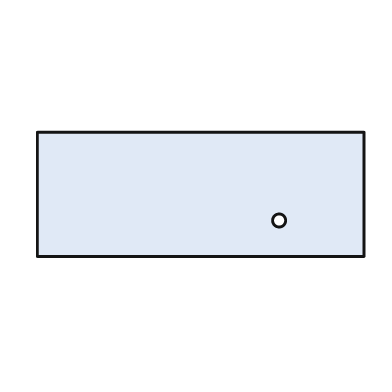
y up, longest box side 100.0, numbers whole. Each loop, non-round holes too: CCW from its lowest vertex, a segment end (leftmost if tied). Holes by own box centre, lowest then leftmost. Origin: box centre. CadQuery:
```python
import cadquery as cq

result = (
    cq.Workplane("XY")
    .moveTo(-50.0, -19.0)
    .lineTo(50.0, -19.0)
    .lineTo(50.0, 19.0)
    .lineTo(-50.0, 19.0)
    .close()
    .moveTo(24.0, -8.0)
    .circle(2.0)
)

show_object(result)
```